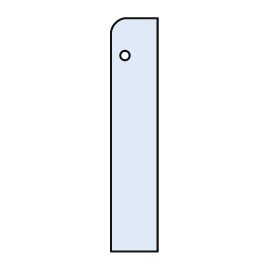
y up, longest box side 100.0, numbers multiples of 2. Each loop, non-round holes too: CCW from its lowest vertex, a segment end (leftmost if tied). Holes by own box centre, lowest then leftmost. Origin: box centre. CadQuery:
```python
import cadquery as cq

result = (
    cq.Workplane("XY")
    .moveTo(-10.0, -50.0)
    .lineTo(10.0, -50.0)
    .lineTo(10.0, 50.0)
    .lineTo(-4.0, 50.0)
    .threePointArc((-8.0, 48.0), (-10.0, 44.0))
    .close()
    .moveTo(-4.0, 34.0)
    .circle(2.0)
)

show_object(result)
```